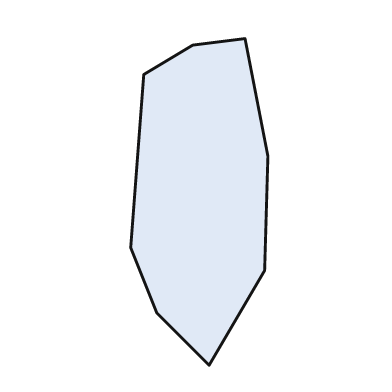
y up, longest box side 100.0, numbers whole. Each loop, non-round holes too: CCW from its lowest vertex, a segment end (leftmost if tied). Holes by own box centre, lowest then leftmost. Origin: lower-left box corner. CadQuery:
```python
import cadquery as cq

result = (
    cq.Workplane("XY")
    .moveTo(24.0, 0.0)
    .lineTo(41.0, 29.0)
    .lineTo(42.0, 64.0)
    .lineTo(35.0, 100.0)
    .lineTo(19.0, 98.0)
    .lineTo(4.0, 89.0)
    .lineTo(0.0, 36.0)
    .lineTo(8.0, 16.0)
    .close()
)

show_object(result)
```